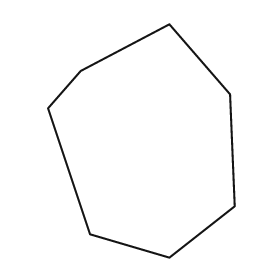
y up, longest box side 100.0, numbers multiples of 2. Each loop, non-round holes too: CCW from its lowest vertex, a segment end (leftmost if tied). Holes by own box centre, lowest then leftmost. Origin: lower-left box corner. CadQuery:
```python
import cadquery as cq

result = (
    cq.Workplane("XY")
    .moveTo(52.0, 0.0)
    .lineTo(80.0, 22.0)
    .lineTo(78.0, 70.0)
    .lineTo(52.0, 100.0)
    .lineTo(14.0, 80.0)
    .lineTo(0.0, 64.0)
    .lineTo(18.0, 10.0)
    .close()
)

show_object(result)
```